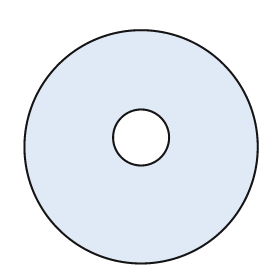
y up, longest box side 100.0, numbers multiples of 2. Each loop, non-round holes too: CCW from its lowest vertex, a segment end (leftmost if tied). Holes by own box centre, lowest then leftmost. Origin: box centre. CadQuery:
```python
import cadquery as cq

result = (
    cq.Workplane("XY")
    .moveTo(0.0, 0.0)
    .circle(50.0)
    .moveTo(0.0, 4.0)
    .circle(12.0)
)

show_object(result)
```